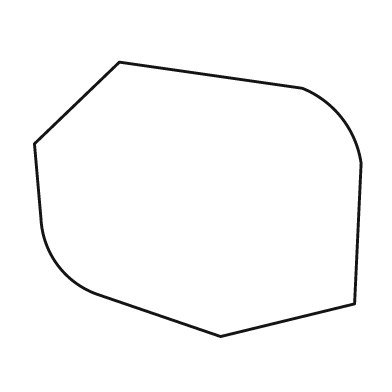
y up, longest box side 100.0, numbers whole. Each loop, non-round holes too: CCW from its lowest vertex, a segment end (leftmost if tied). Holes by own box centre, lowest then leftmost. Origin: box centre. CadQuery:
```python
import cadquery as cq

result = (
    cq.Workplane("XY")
    .moveTo(7.0, -42.0)
    .lineTo(48.0, -32.0)
    .lineTo(50.0, 11.0)
    .threePointArc((44.0, 25.0), (32.0, 34.0))
    .lineTo(-24.0, 42.0)
    .lineTo(-50.0, 17.0)
    .lineTo(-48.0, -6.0)
    .threePointArc((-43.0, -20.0), (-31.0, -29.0))
    .close()
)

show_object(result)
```